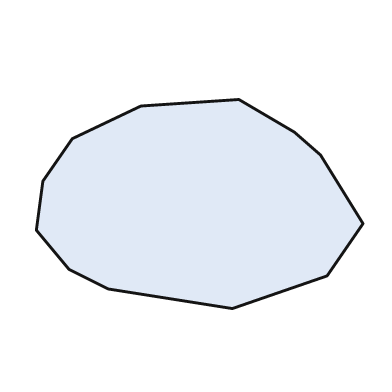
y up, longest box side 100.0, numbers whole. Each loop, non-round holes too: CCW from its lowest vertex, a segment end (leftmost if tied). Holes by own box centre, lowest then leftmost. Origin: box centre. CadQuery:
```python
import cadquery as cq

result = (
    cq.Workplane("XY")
    .moveTo(10.0, -32.0)
    .lineTo(39.0, -22.0)
    .lineTo(50.0, -6.0)
    .lineTo(37.0, 15.0)
    .lineTo(29.0, 22.0)
    .lineTo(12.0, 32.0)
    .lineTo(-18.0, 30.0)
    .lineTo(-39.0, 20.0)
    .lineTo(-48.0, 7.0)
    .lineTo(-50.0, -8.0)
    .lineTo(-40.0, -20.0)
    .lineTo(-28.0, -26.0)
    .close()
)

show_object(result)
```